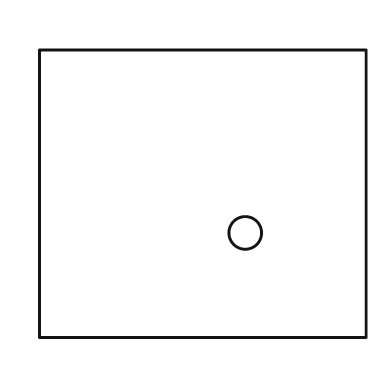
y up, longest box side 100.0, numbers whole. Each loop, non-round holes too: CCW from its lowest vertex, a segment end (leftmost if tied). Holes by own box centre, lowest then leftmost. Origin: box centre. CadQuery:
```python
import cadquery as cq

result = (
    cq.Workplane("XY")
    .moveTo(-50.0, -44.0)
    .lineTo(50.0, -44.0)
    .lineTo(50.0, 44.0)
    .lineTo(-50.0, 44.0)
    .close()
    .moveTo(13.0, -12.0)
    .circle(5.0)
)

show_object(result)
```